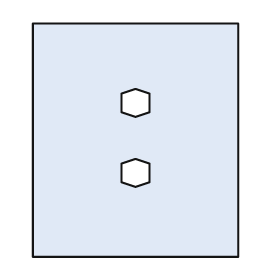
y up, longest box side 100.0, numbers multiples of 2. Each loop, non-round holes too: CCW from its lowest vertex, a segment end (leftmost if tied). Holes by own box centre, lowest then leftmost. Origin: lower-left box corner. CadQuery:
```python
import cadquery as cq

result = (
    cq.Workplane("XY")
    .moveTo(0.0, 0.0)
    .lineTo(88.0, 0.0)
    .lineTo(88.0, 100.0)
    .lineTo(0.0, 100.0)
    .close()
    .moveTo(44.0, 30.0)
    .lineTo(50.0, 32.0)
    .lineTo(50.0, 40.0)
    .lineTo(44.0, 42.0)
    .lineTo(38.0, 40.0)
    .lineTo(38.0, 32.0)
    .close()
    .moveTo(44.0, 60.0)
    .lineTo(50.0, 62.0)
    .lineTo(50.0, 70.0)
    .lineTo(44.0, 72.0)
    .lineTo(38.0, 70.0)
    .lineTo(38.0, 62.0)
    .close()
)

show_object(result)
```